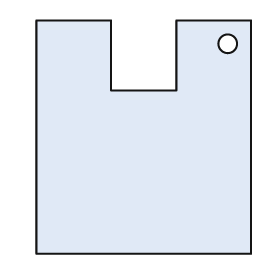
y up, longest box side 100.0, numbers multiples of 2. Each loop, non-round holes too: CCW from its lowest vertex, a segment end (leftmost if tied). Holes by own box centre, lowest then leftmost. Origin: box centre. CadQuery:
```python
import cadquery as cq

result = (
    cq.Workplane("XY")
    .moveTo(-46.0, -50.0)
    .lineTo(46.0, -50.0)
    .lineTo(46.0, 50.0)
    .lineTo(14.0, 50.0)
    .lineTo(14.0, 20.0)
    .lineTo(-14.0, 20.0)
    .lineTo(-14.0, 50.0)
    .lineTo(-46.0, 50.0)
    .close()
    .moveTo(36.0, 40.0)
    .circle(4.0)
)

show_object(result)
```